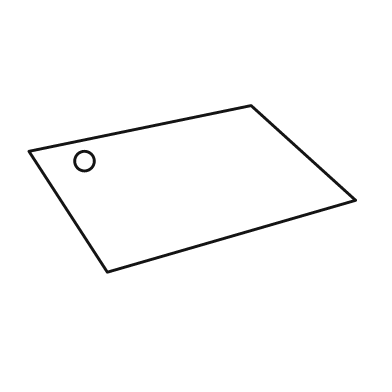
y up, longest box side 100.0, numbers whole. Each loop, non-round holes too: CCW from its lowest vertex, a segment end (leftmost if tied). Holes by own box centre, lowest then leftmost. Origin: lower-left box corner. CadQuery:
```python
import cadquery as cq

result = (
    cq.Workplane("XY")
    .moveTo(24.0, 0.0)
    .lineTo(100.0, 22.0)
    .lineTo(68.0, 51.0)
    .lineTo(0.0, 37.0)
    .close()
    .moveTo(17.0, 34.0)
    .circle(3.0)
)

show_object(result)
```